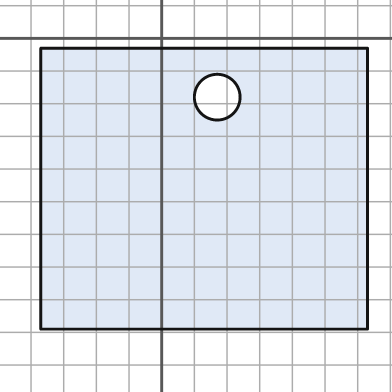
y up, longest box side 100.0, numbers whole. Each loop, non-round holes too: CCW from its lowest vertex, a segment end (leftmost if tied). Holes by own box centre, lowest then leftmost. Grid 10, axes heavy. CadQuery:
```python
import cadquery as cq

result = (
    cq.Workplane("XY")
    .moveTo(-37.0, -89.0)
    .lineTo(63.0, -89.0)
    .lineTo(63.0, -3.0)
    .lineTo(-37.0, -3.0)
    .close()
    .moveTo(17.0, -18.0)
    .circle(7.0)
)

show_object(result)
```